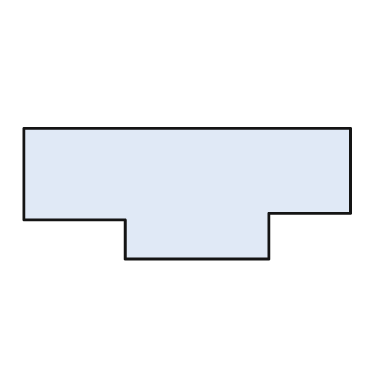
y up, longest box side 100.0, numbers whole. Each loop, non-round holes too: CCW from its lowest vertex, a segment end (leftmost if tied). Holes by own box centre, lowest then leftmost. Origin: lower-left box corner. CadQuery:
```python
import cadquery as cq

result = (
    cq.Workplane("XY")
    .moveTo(31.0, 0.0)
    .lineTo(75.0, 0.0)
    .lineTo(75.0, 14.0)
    .lineTo(100.0, 14.0)
    .lineTo(100.0, 40.0)
    .lineTo(0.0, 40.0)
    .lineTo(0.0, 12.0)
    .lineTo(31.0, 12.0)
    .close()
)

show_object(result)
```